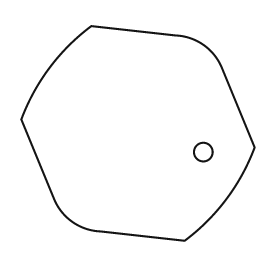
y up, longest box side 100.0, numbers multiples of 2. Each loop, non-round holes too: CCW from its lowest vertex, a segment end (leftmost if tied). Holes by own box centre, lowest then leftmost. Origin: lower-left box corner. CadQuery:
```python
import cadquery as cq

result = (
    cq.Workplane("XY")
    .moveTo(70.0, 0.0)
    .threePointArc((88.0, 18.0), (100.0, 40.0))
    .lineTo(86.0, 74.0)
    .threePointArc((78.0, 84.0), (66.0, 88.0))
    .lineTo(30.0, 92.0)
    .threePointArc((12.0, 74.0), (0.0, 52.0))
    .lineTo(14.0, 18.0)
    .threePointArc((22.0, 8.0), (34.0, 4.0))
    .close()
    .moveTo(78.0, 38.0)
    .circle(4.0)
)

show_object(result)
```